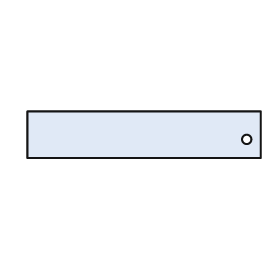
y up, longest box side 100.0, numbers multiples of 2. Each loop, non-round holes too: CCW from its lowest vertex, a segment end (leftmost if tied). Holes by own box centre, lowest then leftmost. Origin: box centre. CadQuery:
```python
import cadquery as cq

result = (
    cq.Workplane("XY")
    .moveTo(-50.0, -10.0)
    .lineTo(50.0, -10.0)
    .lineTo(50.0, 10.0)
    .lineTo(-50.0, 10.0)
    .close()
    .moveTo(44.0, -2.0)
    .circle(2.0)
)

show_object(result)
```